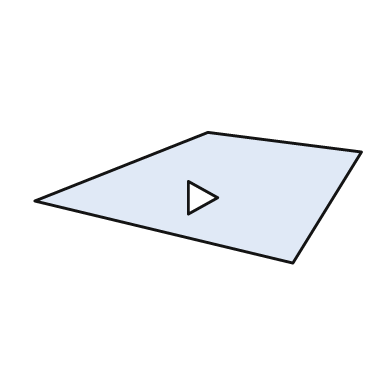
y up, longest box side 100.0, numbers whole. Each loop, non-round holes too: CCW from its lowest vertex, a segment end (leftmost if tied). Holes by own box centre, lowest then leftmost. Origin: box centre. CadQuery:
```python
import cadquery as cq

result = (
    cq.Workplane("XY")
    .moveTo(29.0, -20.0)
    .lineTo(50.0, 14.0)
    .lineTo(3.0, 20.0)
    .lineTo(-50.0, -1.0)
    .close()
    .moveTo(-3.0, -5.0)
    .lineTo(6.0, 0.0)
    .lineTo(-3.0, 5.0)
    .close()
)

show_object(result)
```